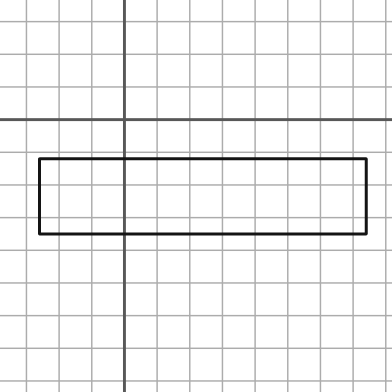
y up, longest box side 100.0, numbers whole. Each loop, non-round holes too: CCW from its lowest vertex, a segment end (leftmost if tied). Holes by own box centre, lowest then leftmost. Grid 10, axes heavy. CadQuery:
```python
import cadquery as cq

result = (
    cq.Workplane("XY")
    .moveTo(-26.0, -35.0)
    .lineTo(74.0, -35.0)
    .lineTo(74.0, -12.0)
    .lineTo(-26.0, -12.0)
    .close()
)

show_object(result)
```